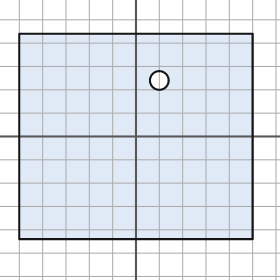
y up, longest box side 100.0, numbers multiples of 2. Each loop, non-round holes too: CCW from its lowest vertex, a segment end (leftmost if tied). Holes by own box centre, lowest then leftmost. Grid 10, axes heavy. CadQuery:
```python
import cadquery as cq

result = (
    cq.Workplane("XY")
    .moveTo(-50.0, -44.0)
    .lineTo(50.0, -44.0)
    .lineTo(50.0, 44.0)
    .lineTo(-50.0, 44.0)
    .close()
    .moveTo(10.0, 24.0)
    .circle(4.0)
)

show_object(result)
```